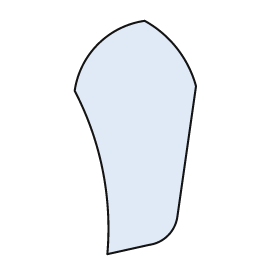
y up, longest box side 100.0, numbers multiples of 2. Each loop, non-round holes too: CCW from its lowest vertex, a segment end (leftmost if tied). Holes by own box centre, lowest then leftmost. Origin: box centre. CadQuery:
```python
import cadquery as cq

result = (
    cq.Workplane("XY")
    .moveTo(-12.0, -50.0)
    .lineTo(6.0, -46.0)
    .threePointArc((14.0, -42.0), (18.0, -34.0))
    .lineTo(26.0, 22.0)
    .threePointArc((18.0, 38.0), (4.0, 50.0))
    .threePointArc((-16.0, 40.0), (-26.0, 20.0))
    .threePointArc((-14.0, -14.0), (-12.0, -50.0))
    .close()
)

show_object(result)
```